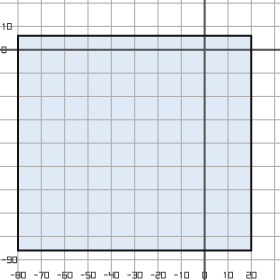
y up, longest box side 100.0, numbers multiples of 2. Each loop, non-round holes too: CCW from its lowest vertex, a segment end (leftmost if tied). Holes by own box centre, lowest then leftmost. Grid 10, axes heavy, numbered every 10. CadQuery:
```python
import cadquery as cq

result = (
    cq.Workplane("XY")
    .moveTo(-80.0, -86.0)
    .lineTo(20.0, -86.0)
    .lineTo(20.0, 6.0)
    .lineTo(-80.0, 6.0)
    .close()
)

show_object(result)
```